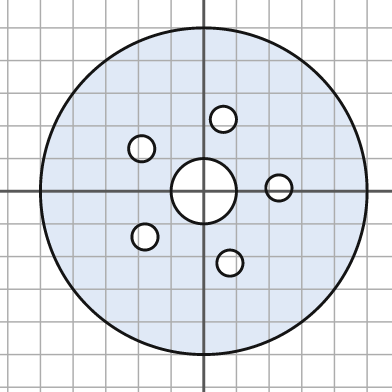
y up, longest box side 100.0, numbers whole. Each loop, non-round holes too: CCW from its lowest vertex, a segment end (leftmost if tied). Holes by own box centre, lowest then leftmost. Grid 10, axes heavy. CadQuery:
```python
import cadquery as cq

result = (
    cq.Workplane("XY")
    .moveTo(0.0, 0.0)
    .circle(50.0)
    .moveTo(8.0, -22.0)
    .circle(4.0)
    .moveTo(-18.0, -14.0)
    .circle(4.0)
    .moveTo(0.0, 0.0)
    .circle(10.0)
    .moveTo(23.0, 1.0)
    .circle(4.0)
    .moveTo(-19.0, 13.0)
    .circle(4.0)
    .moveTo(6.0, 22.0)
    .circle(4.0)
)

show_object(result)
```